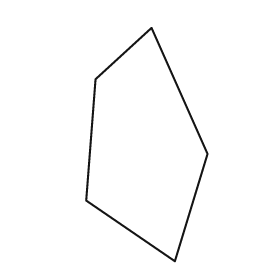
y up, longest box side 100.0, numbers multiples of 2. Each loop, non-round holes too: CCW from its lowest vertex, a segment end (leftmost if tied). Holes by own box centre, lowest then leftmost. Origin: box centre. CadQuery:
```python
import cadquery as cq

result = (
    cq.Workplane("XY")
    .moveTo(12.0, -50.0)
    .lineTo(26.0, -4.0)
    .lineTo(2.0, 50.0)
    .lineTo(-22.0, 28.0)
    .lineTo(-26.0, -24.0)
    .close()
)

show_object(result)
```